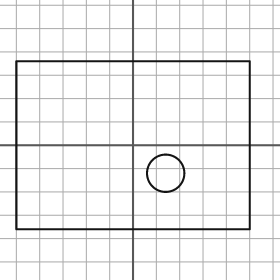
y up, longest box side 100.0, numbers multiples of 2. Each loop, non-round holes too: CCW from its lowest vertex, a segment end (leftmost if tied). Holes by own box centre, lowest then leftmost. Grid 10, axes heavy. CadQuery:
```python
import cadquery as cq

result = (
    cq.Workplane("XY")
    .moveTo(-50.0, -36.0)
    .lineTo(50.0, -36.0)
    .lineTo(50.0, 36.0)
    .lineTo(-50.0, 36.0)
    .close()
    .moveTo(14.0, -12.0)
    .circle(8.0)
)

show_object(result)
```